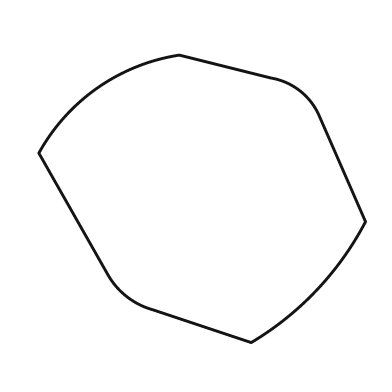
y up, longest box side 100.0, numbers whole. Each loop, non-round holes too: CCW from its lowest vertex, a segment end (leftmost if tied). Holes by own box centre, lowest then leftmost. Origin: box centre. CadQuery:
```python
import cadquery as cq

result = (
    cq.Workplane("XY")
    .moveTo(15.0, -44.0)
    .threePointArc((35.0, -28.0), (50.0, -7.0))
    .lineTo(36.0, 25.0)
    .threePointArc((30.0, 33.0), (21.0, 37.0))
    .lineTo(-7.0, 44.0)
    .threePointArc((-32.0, 34.0), (-50.0, 14.0))
    .lineTo(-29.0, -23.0)
    .threePointArc((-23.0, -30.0), (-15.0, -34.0))
    .close()
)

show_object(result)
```